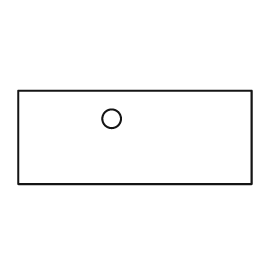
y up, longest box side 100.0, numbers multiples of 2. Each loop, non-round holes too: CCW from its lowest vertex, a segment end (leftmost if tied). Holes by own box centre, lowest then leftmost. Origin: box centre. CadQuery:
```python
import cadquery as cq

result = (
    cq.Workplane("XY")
    .moveTo(-50.0, -20.0)
    .lineTo(50.0, -20.0)
    .lineTo(50.0, 20.0)
    .lineTo(-50.0, 20.0)
    .close()
    .moveTo(-10.0, 8.0)
    .circle(4.0)
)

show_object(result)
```